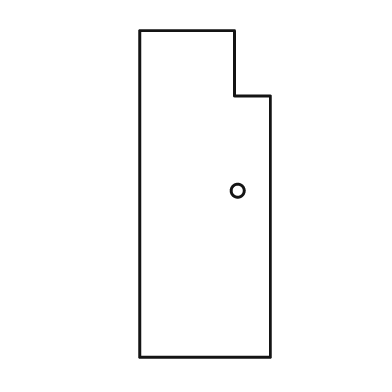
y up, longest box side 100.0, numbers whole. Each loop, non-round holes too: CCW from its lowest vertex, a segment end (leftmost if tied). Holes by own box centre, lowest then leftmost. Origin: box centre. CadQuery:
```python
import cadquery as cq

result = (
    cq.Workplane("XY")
    .moveTo(-20.0, -50.0)
    .lineTo(20.0, -50.0)
    .lineTo(20.0, 30.0)
    .lineTo(9.0, 30.0)
    .lineTo(9.0, 50.0)
    .lineTo(-20.0, 50.0)
    .close()
    .moveTo(10.0, 1.0)
    .circle(2.0)
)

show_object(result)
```